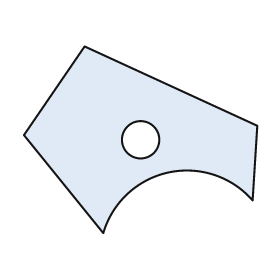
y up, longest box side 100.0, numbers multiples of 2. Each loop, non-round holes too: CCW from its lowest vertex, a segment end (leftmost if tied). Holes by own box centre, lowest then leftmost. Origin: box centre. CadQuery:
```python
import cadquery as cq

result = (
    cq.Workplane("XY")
    .moveTo(-16.0, -40.0)
    .threePointArc((12.0, -14.0), (48.0, -26.0))
    .lineTo(50.0, 6.0)
    .lineTo(-24.0, 40.0)
    .lineTo(-50.0, 2.0)
    .close()
    .moveTo(0.0, 0.0)
    .circle(8.0)
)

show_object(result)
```